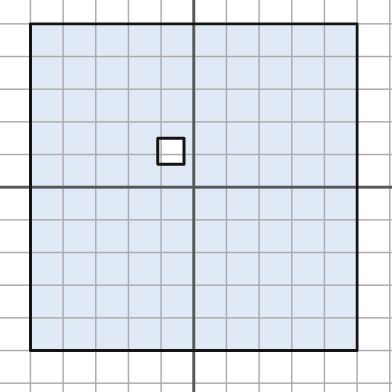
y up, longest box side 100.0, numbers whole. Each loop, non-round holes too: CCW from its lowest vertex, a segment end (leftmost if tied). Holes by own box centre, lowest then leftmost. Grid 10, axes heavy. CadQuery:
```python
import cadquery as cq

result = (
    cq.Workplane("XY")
    .moveTo(-50.0, -50.0)
    .lineTo(50.0, -50.0)
    .lineTo(50.0, 50.0)
    .lineTo(-50.0, 50.0)
    .close()
    .moveTo(-11.0, 7.0)
    .lineTo(-3.0, 7.0)
    .lineTo(-3.0, 15.0)
    .lineTo(-11.0, 15.0)
    .close()
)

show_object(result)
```